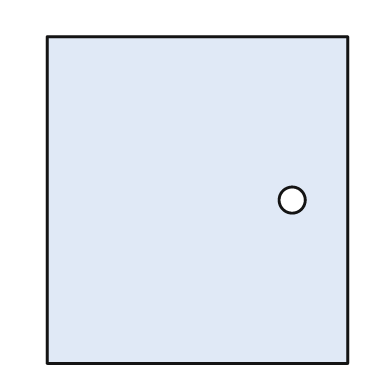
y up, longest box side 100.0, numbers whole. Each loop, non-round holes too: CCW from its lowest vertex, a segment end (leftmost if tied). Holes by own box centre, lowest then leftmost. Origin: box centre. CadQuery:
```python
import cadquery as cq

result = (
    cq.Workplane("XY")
    .moveTo(-46.0, -50.0)
    .lineTo(46.0, -50.0)
    .lineTo(46.0, 50.0)
    .lineTo(-46.0, 50.0)
    .close()
    .moveTo(29.0, 0.0)
    .circle(4.0)
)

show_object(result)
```